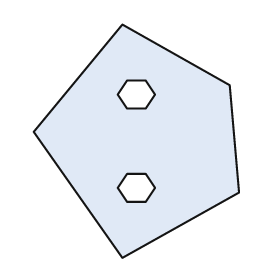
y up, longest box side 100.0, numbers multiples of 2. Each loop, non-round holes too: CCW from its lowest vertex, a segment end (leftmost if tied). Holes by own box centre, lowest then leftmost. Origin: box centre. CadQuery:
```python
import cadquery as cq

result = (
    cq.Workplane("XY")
    .moveTo(-6.0, -50.0)
    .lineTo(44.0, -22.0)
    .lineTo(40.0, 24.0)
    .lineTo(-6.0, 50.0)
    .lineTo(-44.0, 4.0)
    .close()
    .moveTo(-4.0, -26.0)
    .lineTo(4.0, -26.0)
    .lineTo(8.0, -20.0)
    .lineTo(4.0, -14.0)
    .lineTo(-4.0, -14.0)
    .lineTo(-8.0, -20.0)
    .close()
    .moveTo(-4.0, 14.0)
    .lineTo(4.0, 14.0)
    .lineTo(8.0, 20.0)
    .lineTo(4.0, 26.0)
    .lineTo(-4.0, 26.0)
    .lineTo(-8.0, 20.0)
    .close()
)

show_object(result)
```